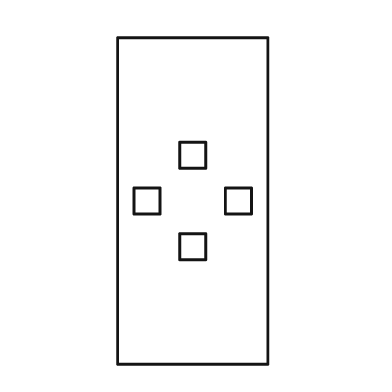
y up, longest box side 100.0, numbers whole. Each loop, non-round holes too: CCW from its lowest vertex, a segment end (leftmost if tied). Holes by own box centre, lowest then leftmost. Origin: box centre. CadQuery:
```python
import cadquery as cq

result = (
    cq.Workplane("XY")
    .moveTo(-23.0, -50.0)
    .lineTo(23.0, -50.0)
    .lineTo(23.0, 50.0)
    .lineTo(-23.0, 50.0)
    .close()
    .moveTo(-4.0, -18.0)
    .lineTo(4.0, -18.0)
    .lineTo(4.0, -10.0)
    .lineTo(-4.0, -10.0)
    .close()
    .moveTo(-18.0, -4.0)
    .lineTo(-10.0, -4.0)
    .lineTo(-10.0, 4.0)
    .lineTo(-18.0, 4.0)
    .close()
    .moveTo(10.0, -4.0)
    .lineTo(18.0, -4.0)
    .lineTo(18.0, 4.0)
    .lineTo(10.0, 4.0)
    .close()
    .moveTo(-4.0, 10.0)
    .lineTo(4.0, 10.0)
    .lineTo(4.0, 18.0)
    .lineTo(-4.0, 18.0)
    .close()
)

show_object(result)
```